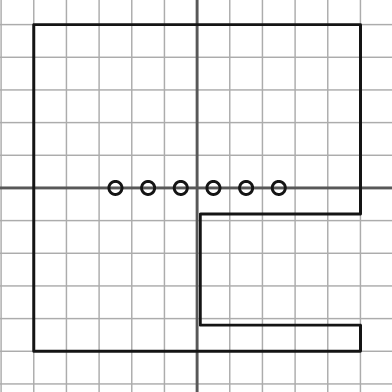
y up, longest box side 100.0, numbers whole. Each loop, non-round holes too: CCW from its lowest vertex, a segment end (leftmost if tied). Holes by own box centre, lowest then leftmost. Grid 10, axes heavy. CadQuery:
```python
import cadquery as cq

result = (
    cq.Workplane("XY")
    .moveTo(-50.0, -50.0)
    .lineTo(50.0, -50.0)
    .lineTo(50.0, -42.0)
    .lineTo(1.0, -42.0)
    .lineTo(1.0, -8.0)
    .lineTo(50.0, -8.0)
    .lineTo(50.0, 50.0)
    .lineTo(-50.0, 50.0)
    .close()
    .moveTo(-25.0, 0.0)
    .circle(2.0)
    .moveTo(-15.0, 0.0)
    .circle(2.0)
    .moveTo(-5.0, 0.0)
    .circle(2.0)
    .moveTo(5.0, 0.0)
    .circle(2.0)
    .moveTo(15.0, 0.0)
    .circle(2.0)
    .moveTo(25.0, 0.0)
    .circle(2.0)
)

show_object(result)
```